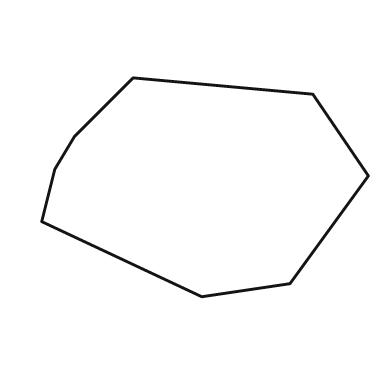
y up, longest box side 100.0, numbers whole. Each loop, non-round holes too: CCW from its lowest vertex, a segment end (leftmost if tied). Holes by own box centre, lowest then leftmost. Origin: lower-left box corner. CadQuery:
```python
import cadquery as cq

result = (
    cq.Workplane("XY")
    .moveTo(49.0, 0.0)
    .lineTo(76.0, 4.0)
    .lineTo(100.0, 37.0)
    .lineTo(83.0, 62.0)
    .lineTo(28.0, 67.0)
    .lineTo(10.0, 49.0)
    .lineTo(4.0, 39.0)
    .lineTo(0.0, 23.0)
    .close()
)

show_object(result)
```